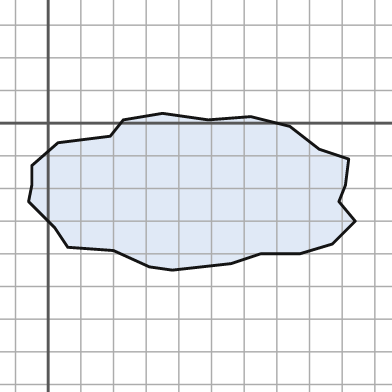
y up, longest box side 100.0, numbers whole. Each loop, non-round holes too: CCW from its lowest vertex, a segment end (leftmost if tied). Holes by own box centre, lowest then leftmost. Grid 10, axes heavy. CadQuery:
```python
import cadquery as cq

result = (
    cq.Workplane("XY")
    .moveTo(38.0, -45.0)
    .lineTo(56.0, -43.0)
    .lineTo(65.0, -40.0)
    .lineTo(77.0, -40.0)
    .lineTo(87.0, -37.0)
    .lineTo(94.0, -30.0)
    .lineTo(89.0, -24.0)
    .lineTo(91.0, -19.0)
    .lineTo(92.0, -11.0)
    .lineTo(83.0, -8.0)
    .lineTo(74.0, -1.0)
    .lineTo(62.0, 2.0)
    .lineTo(49.0, 1.0)
    .lineTo(35.0, 3.0)
    .lineTo(23.0, 1.0)
    .lineTo(19.0, -4.0)
    .lineTo(3.0, -6.0)
    .lineTo(-5.0, -13.0)
    .lineTo(-5.0, -19.0)
    .lineTo(-6.0, -24.0)
    .lineTo(2.0, -32.0)
    .lineTo(6.0, -38.0)
    .lineTo(20.0, -39.0)
    .lineTo(31.0, -44.0)
    .close()
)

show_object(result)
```